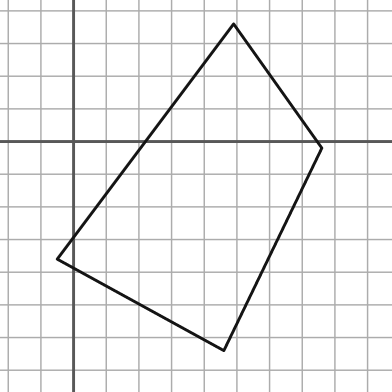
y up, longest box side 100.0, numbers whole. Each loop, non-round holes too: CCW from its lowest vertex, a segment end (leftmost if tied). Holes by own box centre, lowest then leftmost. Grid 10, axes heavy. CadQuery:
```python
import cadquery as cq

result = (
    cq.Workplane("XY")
    .moveTo(46.0, -64.0)
    .lineTo(76.0, -2.0)
    .lineTo(49.0, 36.0)
    .lineTo(-5.0, -36.0)
    .close()
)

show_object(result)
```